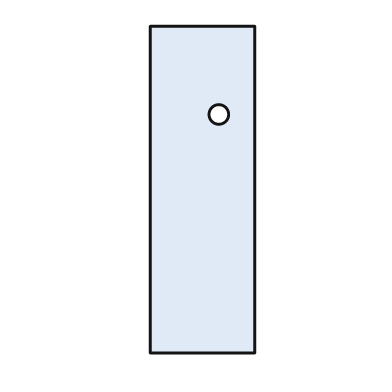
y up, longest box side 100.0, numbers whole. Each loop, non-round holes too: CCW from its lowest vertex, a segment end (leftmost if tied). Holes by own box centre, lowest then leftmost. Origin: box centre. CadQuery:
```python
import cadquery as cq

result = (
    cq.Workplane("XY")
    .moveTo(-16.0, -50.0)
    .lineTo(16.0, -50.0)
    .lineTo(16.0, 50.0)
    .lineTo(-16.0, 50.0)
    .close()
    .moveTo(5.0, 23.0)
    .circle(3.0)
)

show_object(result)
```